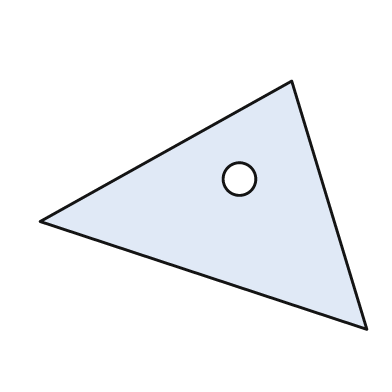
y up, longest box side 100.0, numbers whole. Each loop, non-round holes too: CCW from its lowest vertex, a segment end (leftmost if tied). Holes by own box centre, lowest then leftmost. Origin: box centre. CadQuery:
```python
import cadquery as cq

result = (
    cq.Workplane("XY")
    .moveTo(50.0, -38.0)
    .lineTo(27.0, 38.0)
    .lineTo(-50.0, -5.0)
    .close()
    .moveTo(11.0, 8.0)
    .circle(5.0)
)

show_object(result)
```